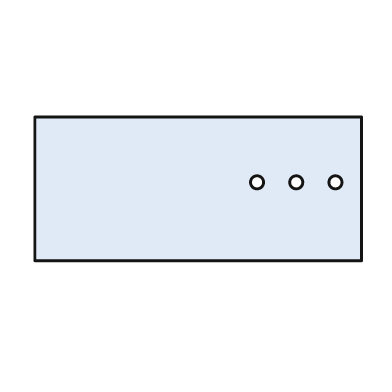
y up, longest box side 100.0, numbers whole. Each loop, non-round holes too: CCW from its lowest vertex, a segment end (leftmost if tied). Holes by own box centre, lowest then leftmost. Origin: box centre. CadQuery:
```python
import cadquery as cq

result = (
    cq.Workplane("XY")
    .moveTo(-50.0, -22.0)
    .lineTo(50.0, -22.0)
    .lineTo(50.0, 22.0)
    .lineTo(-50.0, 22.0)
    .close()
    .moveTo(18.0, 2.0)
    .circle(2.0)
    .moveTo(30.0, 2.0)
    .circle(2.0)
    .moveTo(42.0, 2.0)
    .circle(2.0)
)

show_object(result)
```